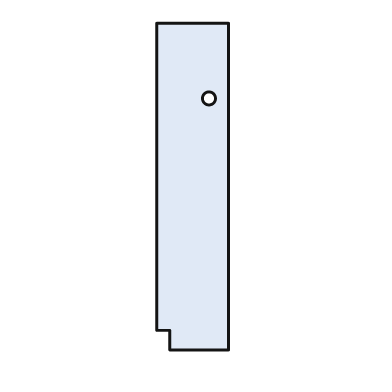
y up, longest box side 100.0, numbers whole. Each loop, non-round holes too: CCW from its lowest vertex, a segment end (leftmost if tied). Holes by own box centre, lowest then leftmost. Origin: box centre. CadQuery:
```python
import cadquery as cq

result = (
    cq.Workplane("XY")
    .moveTo(-7.0, -50.0)
    .lineTo(11.0, -50.0)
    .lineTo(11.0, 50.0)
    .lineTo(-11.0, 50.0)
    .lineTo(-11.0, -44.0)
    .lineTo(-7.0, -44.0)
    .close()
    .moveTo(5.0, 27.0)
    .circle(2.0)
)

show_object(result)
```